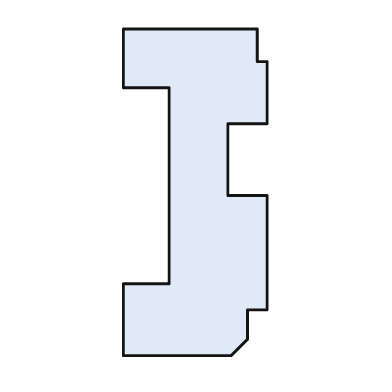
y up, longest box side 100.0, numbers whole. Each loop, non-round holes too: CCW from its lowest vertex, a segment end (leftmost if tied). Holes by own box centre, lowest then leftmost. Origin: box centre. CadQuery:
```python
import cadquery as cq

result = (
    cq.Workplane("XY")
    .moveTo(-22.0, -50.0)
    .lineTo(11.0, -50.0)
    .lineTo(16.0, -45.0)
    .lineTo(16.0, -36.0)
    .lineTo(22.0, -36.0)
    .lineTo(22.0, -1.0)
    .lineTo(10.0, -1.0)
    .lineTo(10.0, 21.0)
    .lineTo(22.0, 21.0)
    .lineTo(22.0, 40.0)
    .lineTo(19.0, 40.0)
    .lineTo(19.0, 50.0)
    .lineTo(-22.0, 50.0)
    .lineTo(-22.0, 32.0)
    .lineTo(-8.0, 32.0)
    .lineTo(-8.0, -28.0)
    .lineTo(-22.0, -28.0)
    .close()
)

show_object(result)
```